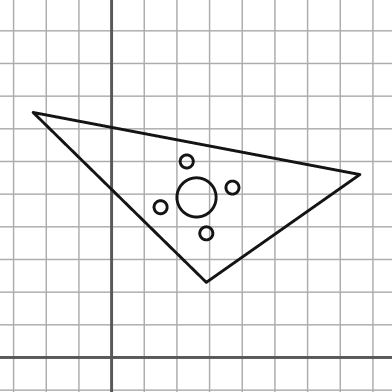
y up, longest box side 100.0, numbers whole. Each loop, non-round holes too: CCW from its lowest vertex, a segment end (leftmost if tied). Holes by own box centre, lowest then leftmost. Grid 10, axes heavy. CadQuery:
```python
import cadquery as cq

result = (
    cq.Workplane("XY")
    .moveTo(29.0, 23.0)
    .lineTo(76.0, 56.0)
    .lineTo(-24.0, 75.0)
    .close()
    .moveTo(29.0, 38.0)
    .circle(2.0)
    .moveTo(15.0, 46.0)
    .circle(2.0)
    .moveTo(26.0, 49.0)
    .circle(6.0)
    .moveTo(37.0, 52.0)
    .circle(2.0)
    .moveTo(23.0, 60.0)
    .circle(2.0)
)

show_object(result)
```